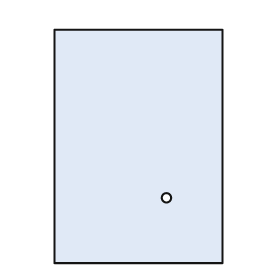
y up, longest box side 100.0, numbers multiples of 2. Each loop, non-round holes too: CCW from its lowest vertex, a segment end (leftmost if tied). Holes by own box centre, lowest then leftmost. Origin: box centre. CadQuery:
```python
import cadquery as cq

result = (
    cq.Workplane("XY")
    .moveTo(-36.0, -50.0)
    .lineTo(36.0, -50.0)
    .lineTo(36.0, 50.0)
    .lineTo(-36.0, 50.0)
    .close()
    .moveTo(12.0, -22.0)
    .circle(2.0)
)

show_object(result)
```